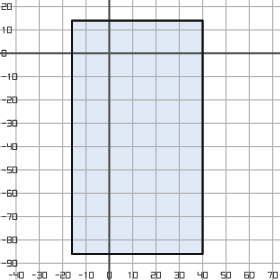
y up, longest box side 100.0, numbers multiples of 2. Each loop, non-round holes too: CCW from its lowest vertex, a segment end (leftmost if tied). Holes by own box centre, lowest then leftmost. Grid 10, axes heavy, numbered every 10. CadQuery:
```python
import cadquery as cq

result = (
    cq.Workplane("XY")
    .moveTo(-16.0, -86.0)
    .lineTo(40.0, -86.0)
    .lineTo(40.0, 14.0)
    .lineTo(-16.0, 14.0)
    .close()
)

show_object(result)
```